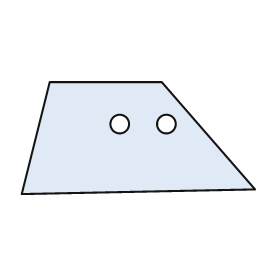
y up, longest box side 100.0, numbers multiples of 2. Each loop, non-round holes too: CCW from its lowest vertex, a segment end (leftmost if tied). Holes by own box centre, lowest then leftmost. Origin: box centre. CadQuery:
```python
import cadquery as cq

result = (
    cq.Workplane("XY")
    .moveTo(-50.0, -24.0)
    .lineTo(50.0, -22.0)
    .lineTo(10.0, 24.0)
    .lineTo(-38.0, 24.0)
    .close()
    .moveTo(-8.0, 6.0)
    .circle(4.0)
    .moveTo(12.0, 6.0)
    .circle(4.0)
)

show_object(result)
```